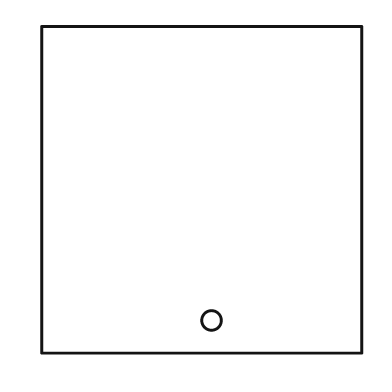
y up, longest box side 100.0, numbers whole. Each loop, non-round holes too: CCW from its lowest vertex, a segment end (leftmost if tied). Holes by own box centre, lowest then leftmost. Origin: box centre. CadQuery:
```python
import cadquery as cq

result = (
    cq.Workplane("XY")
    .moveTo(-49.0, -50.0)
    .lineTo(49.0, -50.0)
    .lineTo(49.0, 50.0)
    .lineTo(-49.0, 50.0)
    .close()
    .moveTo(3.0, -40.0)
    .circle(3.0)
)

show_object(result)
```